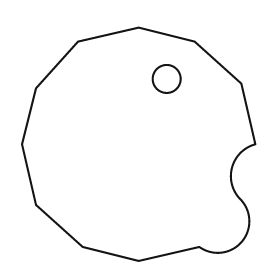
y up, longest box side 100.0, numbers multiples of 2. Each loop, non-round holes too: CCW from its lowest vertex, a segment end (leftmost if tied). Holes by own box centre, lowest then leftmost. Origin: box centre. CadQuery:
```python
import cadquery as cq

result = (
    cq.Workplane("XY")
    .moveTo(0.0, -50.0)
    .lineTo(26.0, -44.0)
    .threePointArc((44.0, -42.0), (44.0, -24.0))
    .threePointArc((40.0, -10.0), (50.0, 0.0))
    .lineTo(44.0, 26.0)
    .lineTo(24.0, 44.0)
    .lineTo(0.0, 50.0)
    .lineTo(-26.0, 44.0)
    .lineTo(-44.0, 24.0)
    .lineTo(-50.0, 0.0)
    .lineTo(-44.0, -26.0)
    .lineTo(-24.0, -44.0)
    .close()
    .moveTo(12.0, 28.0)
    .circle(6.0)
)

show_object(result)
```